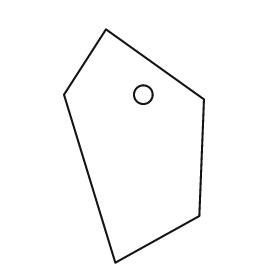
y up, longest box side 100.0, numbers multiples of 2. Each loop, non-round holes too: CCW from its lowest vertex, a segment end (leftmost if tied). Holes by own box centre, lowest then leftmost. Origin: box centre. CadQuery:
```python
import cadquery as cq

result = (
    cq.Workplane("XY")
    .moveTo(-8.0, -50.0)
    .lineTo(28.0, -30.0)
    .lineTo(30.0, 20.0)
    .lineTo(-12.0, 50.0)
    .lineTo(-30.0, 22.0)
    .close()
    .moveTo(4.0, 22.0)
    .circle(4.0)
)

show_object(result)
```